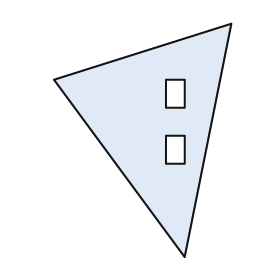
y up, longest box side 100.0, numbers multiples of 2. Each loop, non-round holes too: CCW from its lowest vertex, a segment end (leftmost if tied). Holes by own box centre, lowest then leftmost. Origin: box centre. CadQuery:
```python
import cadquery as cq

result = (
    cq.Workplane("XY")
    .moveTo(18.0, -50.0)
    .lineTo(38.0, 50.0)
    .lineTo(-38.0, 26.0)
    .close()
    .moveTo(10.0, -10.0)
    .lineTo(18.0, -10.0)
    .lineTo(18.0, 2.0)
    .lineTo(10.0, 2.0)
    .close()
    .moveTo(10.0, 14.0)
    .lineTo(18.0, 14.0)
    .lineTo(18.0, 26.0)
    .lineTo(10.0, 26.0)
    .close()
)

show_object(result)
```